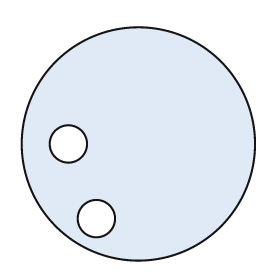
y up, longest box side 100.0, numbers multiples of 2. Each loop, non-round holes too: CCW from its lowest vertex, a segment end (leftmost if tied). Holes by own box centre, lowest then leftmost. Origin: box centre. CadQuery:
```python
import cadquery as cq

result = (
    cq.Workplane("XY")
    .moveTo(0.0, 0.0)
    .circle(50.0)
    .moveTo(-18.0, -32.0)
    .circle(8.0)
    .moveTo(-30.0, 0.0)
    .circle(8.0)
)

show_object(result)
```